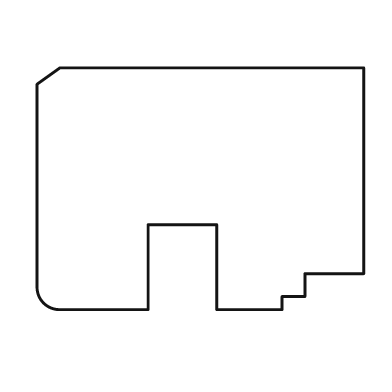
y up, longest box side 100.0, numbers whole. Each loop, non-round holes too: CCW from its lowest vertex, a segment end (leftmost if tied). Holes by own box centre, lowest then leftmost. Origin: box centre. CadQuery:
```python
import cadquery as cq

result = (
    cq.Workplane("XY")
    .moveTo(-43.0, -37.0)
    .lineTo(-16.0, -37.0)
    .lineTo(-16.0, -11.0)
    .lineTo(5.0, -11.0)
    .lineTo(5.0, -37.0)
    .lineTo(25.0, -37.0)
    .lineTo(25.0, -33.0)
    .lineTo(32.0, -33.0)
    .lineTo(32.0, -26.0)
    .lineTo(50.0, -26.0)
    .lineTo(50.0, 37.0)
    .lineTo(-43.0, 37.0)
    .lineTo(-50.0, 32.0)
    .lineTo(-50.0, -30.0)
    .threePointArc((-48.0, -35.0), (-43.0, -37.0))
    .close()
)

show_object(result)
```